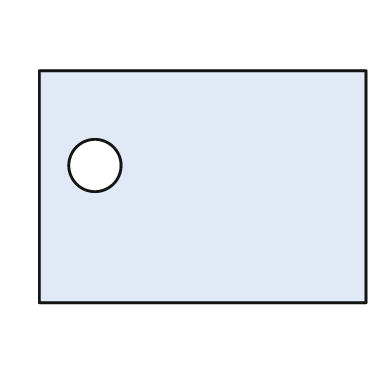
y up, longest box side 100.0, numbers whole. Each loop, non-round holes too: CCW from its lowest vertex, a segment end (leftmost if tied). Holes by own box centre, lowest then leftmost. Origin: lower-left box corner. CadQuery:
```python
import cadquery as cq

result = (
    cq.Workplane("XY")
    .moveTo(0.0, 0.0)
    .lineTo(100.0, 0.0)
    .lineTo(100.0, 71.0)
    .lineTo(0.0, 71.0)
    .close()
    .moveTo(17.0, 42.0)
    .circle(8.0)
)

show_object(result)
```